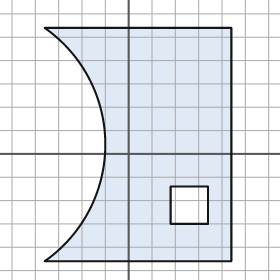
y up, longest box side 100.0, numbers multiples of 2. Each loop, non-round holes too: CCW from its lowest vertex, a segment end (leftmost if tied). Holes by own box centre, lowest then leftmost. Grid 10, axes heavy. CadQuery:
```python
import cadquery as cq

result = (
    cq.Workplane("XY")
    .moveTo(-36.0, -46.0)
    .lineTo(44.0, -46.0)
    .lineTo(44.0, 54.0)
    .lineTo(-36.0, 54.0)
    .threePointArc((-10.0, 4.0), (-36.0, -46.0))
    .close()
    .moveTo(18.0, -30.0)
    .lineTo(34.0, -30.0)
    .lineTo(34.0, -14.0)
    .lineTo(18.0, -14.0)
    .close()
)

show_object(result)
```